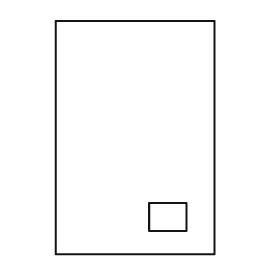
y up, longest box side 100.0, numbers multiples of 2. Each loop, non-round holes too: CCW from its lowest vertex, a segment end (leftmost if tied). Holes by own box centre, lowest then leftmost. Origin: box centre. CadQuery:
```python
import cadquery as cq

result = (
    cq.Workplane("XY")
    .moveTo(-34.0, -50.0)
    .lineTo(34.0, -50.0)
    .lineTo(34.0, 50.0)
    .lineTo(-34.0, 50.0)
    .close()
    .moveTo(6.0, -40.0)
    .lineTo(22.0, -40.0)
    .lineTo(22.0, -28.0)
    .lineTo(6.0, -28.0)
    .close()
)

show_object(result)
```